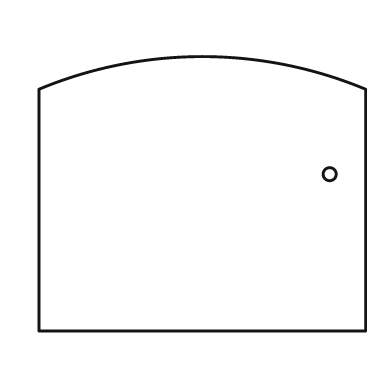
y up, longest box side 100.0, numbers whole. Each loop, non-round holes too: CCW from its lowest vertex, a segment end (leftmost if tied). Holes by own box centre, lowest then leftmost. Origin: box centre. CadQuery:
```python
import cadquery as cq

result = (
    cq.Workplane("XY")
    .moveTo(-50.0, -42.0)
    .lineTo(50.0, -42.0)
    .lineTo(50.0, 32.0)
    .threePointArc((0.0, 42.0), (-50.0, 32.0))
    .close()
    .moveTo(39.0, 6.0)
    .circle(2.0)
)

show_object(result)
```